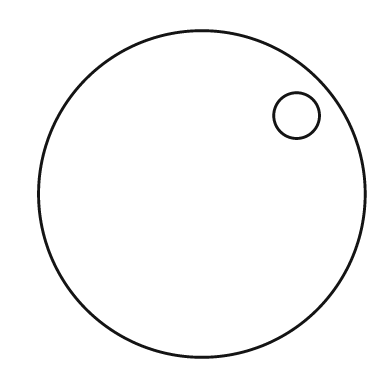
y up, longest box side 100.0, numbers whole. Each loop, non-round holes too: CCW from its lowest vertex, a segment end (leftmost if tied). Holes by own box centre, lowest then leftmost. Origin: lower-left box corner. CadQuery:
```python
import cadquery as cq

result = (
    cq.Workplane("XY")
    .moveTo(50.0, 50.0)
    .circle(50.0)
    .moveTo(79.0, 74.0)
    .circle(7.0)
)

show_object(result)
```